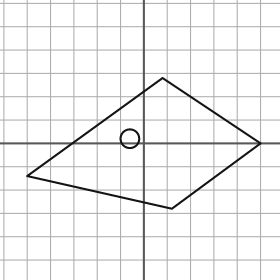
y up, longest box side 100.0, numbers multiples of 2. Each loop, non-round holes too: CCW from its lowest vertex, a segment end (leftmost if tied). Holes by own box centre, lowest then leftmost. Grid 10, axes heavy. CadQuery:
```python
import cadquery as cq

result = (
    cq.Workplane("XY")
    .moveTo(12.0, -28.0)
    .lineTo(50.0, 0.0)
    .lineTo(8.0, 28.0)
    .lineTo(-50.0, -14.0)
    .close()
    .moveTo(-6.0, 2.0)
    .circle(4.0)
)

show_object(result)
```